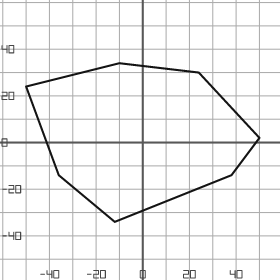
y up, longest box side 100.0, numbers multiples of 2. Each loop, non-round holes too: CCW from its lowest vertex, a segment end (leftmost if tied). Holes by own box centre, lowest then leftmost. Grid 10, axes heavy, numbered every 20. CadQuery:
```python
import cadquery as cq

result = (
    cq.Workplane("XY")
    .moveTo(-12.0, -34.0)
    .lineTo(38.0, -14.0)
    .lineTo(50.0, 2.0)
    .lineTo(24.0, 30.0)
    .lineTo(-10.0, 34.0)
    .lineTo(-50.0, 24.0)
    .lineTo(-36.0, -14.0)
    .close()
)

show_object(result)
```